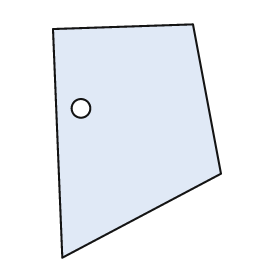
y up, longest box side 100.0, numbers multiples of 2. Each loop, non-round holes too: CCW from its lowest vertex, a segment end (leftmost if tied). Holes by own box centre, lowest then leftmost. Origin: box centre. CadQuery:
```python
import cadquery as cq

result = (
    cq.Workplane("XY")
    .moveTo(-32.0, -50.0)
    .lineTo(36.0, -14.0)
    .lineTo(24.0, 50.0)
    .lineTo(-36.0, 48.0)
    .close()
    .moveTo(-24.0, 14.0)
    .circle(4.0)
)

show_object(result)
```